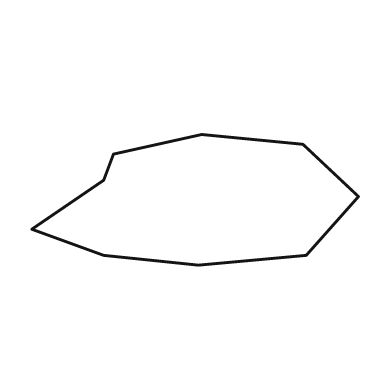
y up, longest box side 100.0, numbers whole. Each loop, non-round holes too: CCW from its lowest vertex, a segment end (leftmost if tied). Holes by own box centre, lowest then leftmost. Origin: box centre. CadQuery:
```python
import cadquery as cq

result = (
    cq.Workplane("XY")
    .moveTo(1.0, -20.0)
    .lineTo(34.0, -17.0)
    .lineTo(50.0, 1.0)
    .lineTo(33.0, 17.0)
    .lineTo(2.0, 20.0)
    .lineTo(-25.0, 14.0)
    .lineTo(-28.0, 6.0)
    .lineTo(-50.0, -9.0)
    .lineTo(-28.0, -17.0)
    .close()
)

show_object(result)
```